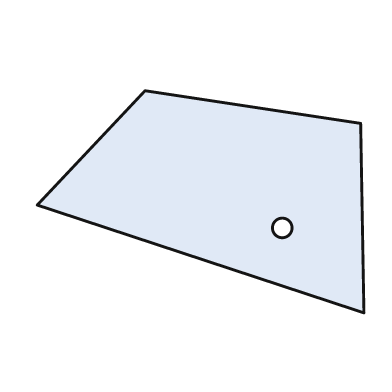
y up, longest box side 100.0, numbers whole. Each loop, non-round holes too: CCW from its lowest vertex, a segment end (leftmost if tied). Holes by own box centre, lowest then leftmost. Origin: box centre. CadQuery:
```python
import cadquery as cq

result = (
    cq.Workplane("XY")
    .moveTo(50.0, -34.0)
    .lineTo(49.0, 24.0)
    .lineTo(-17.0, 34.0)
    .lineTo(-50.0, -1.0)
    .close()
    .moveTo(25.0, -8.0)
    .circle(3.0)
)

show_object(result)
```